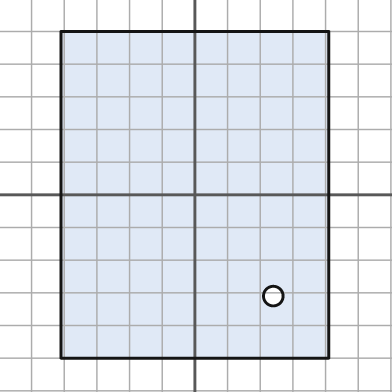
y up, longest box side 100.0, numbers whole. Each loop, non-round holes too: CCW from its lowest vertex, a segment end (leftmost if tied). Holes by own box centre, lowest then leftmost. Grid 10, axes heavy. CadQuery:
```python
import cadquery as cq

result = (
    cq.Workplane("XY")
    .moveTo(-41.0, -50.0)
    .lineTo(41.0, -50.0)
    .lineTo(41.0, 50.0)
    .lineTo(-41.0, 50.0)
    .close()
    .moveTo(24.0, -31.0)
    .circle(3.0)
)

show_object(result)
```